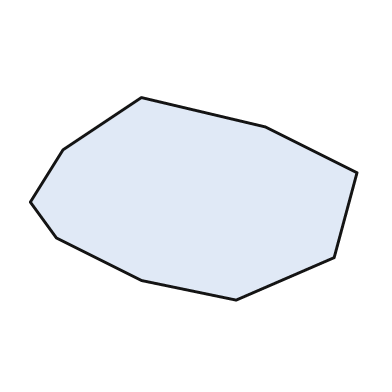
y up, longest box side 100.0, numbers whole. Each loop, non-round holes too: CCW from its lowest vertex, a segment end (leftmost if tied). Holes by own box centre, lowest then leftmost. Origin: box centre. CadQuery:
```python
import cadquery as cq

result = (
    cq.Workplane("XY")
    .moveTo(13.0, -31.0)
    .lineTo(43.0, -18.0)
    .lineTo(50.0, 8.0)
    .lineTo(22.0, 22.0)
    .lineTo(-16.0, 31.0)
    .lineTo(-40.0, 15.0)
    .lineTo(-50.0, -1.0)
    .lineTo(-42.0, -12.0)
    .lineTo(-16.0, -25.0)
    .close()
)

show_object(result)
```